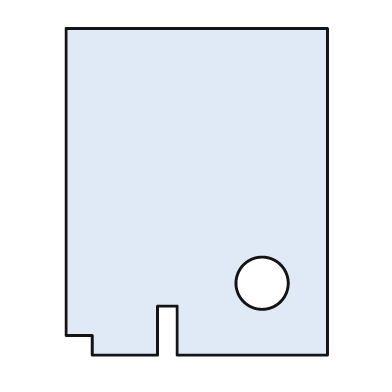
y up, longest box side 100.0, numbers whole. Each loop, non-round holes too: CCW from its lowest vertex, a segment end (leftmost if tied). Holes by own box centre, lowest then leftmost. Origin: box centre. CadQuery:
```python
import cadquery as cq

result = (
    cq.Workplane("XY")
    .moveTo(-32.0, -50.0)
    .lineTo(-12.0, -50.0)
    .lineTo(-12.0, -35.0)
    .lineTo(-6.0, -35.0)
    .lineTo(-6.0, -50.0)
    .lineTo(40.0, -50.0)
    .lineTo(40.0, 50.0)
    .lineTo(-40.0, 50.0)
    .lineTo(-40.0, -44.0)
    .lineTo(-32.0, -44.0)
    .close()
    .moveTo(20.0, -28.0)
    .circle(8.0)
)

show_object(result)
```